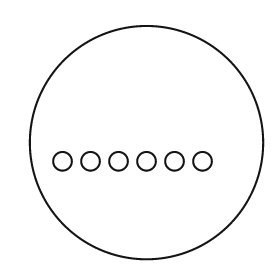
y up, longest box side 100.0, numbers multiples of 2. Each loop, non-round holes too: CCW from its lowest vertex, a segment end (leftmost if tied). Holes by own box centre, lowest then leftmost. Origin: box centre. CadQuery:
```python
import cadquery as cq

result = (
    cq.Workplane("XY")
    .moveTo(0.0, 0.0)
    .circle(50.0)
    .moveTo(-36.0, -8.0)
    .circle(4.0)
    .moveTo(-24.0, -8.0)
    .circle(4.0)
    .moveTo(-12.0, -8.0)
    .circle(4.0)
    .moveTo(0.0, -8.0)
    .circle(4.0)
    .moveTo(12.0, -8.0)
    .circle(4.0)
    .moveTo(24.0, -8.0)
    .circle(4.0)
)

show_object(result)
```